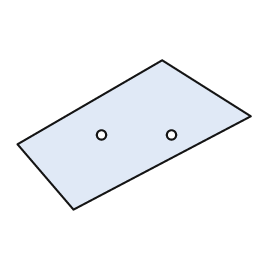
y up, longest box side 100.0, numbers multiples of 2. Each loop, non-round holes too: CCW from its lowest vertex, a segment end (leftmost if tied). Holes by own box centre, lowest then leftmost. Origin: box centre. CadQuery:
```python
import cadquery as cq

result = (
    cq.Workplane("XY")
    .moveTo(-26.0, -32.0)
    .lineTo(50.0, 8.0)
    .lineTo(12.0, 32.0)
    .lineTo(-50.0, -4.0)
    .close()
    .moveTo(-14.0, 0.0)
    .circle(2.0)
    .moveTo(16.0, 0.0)
    .circle(2.0)
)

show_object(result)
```